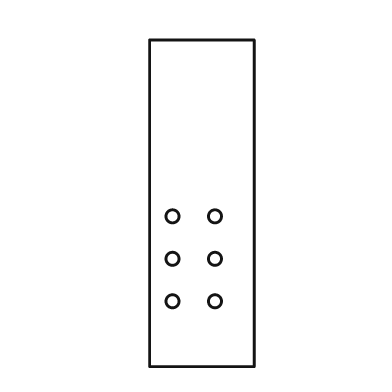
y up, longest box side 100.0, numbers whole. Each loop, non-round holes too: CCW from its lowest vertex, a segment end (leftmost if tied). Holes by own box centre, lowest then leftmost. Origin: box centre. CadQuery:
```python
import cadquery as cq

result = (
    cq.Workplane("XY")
    .moveTo(-16.0, -50.0)
    .lineTo(16.0, -50.0)
    .lineTo(16.0, 50.0)
    .lineTo(-16.0, 50.0)
    .close()
    .moveTo(-9.0, -30.0)
    .circle(2.0)
    .moveTo(4.0, -30.0)
    .circle(2.0)
    .moveTo(-9.0, -17.0)
    .circle(2.0)
    .moveTo(4.0, -17.0)
    .circle(2.0)
    .moveTo(-9.0, -4.0)
    .circle(2.0)
    .moveTo(4.0, -4.0)
    .circle(2.0)
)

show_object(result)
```